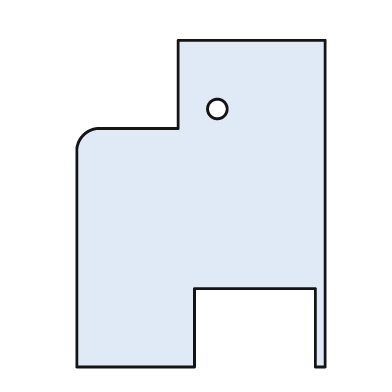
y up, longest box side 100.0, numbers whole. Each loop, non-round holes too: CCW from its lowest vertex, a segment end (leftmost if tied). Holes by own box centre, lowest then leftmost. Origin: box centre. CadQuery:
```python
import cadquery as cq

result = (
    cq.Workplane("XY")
    .moveTo(-38.0, -50.0)
    .lineTo(-2.0, -50.0)
    .lineTo(-2.0, -26.0)
    .lineTo(35.0, -26.0)
    .lineTo(35.0, -50.0)
    .lineTo(38.0, -50.0)
    .lineTo(38.0, 50.0)
    .lineTo(-7.0, 50.0)
    .lineTo(-7.0, 23.0)
    .lineTo(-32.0, 23.0)
    .threePointArc((-36.0, 21.0), (-38.0, 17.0))
    .close()
    .moveTo(5.0, 29.0)
    .circle(3.0)
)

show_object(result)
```